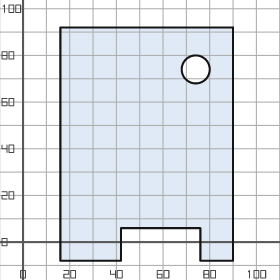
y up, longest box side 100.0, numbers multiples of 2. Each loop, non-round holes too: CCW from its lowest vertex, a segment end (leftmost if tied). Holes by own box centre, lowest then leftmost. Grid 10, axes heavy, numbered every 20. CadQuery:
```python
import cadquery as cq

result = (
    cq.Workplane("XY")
    .moveTo(16.0, -8.0)
    .lineTo(42.0, -8.0)
    .lineTo(42.0, 6.0)
    .lineTo(76.0, 6.0)
    .lineTo(76.0, -8.0)
    .lineTo(90.0, -8.0)
    .lineTo(90.0, 92.0)
    .lineTo(16.0, 92.0)
    .close()
    .moveTo(74.0, 74.0)
    .circle(6.0)
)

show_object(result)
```